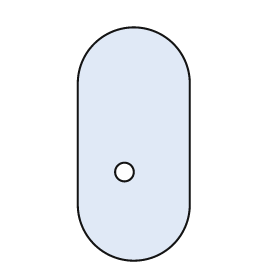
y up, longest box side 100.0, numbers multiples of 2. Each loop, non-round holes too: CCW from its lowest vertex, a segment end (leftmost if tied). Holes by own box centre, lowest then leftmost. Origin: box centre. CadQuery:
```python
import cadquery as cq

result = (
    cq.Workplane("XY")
    .moveTo(-24.0, -26.0)
    .threePointArc((0.0, -50.0), (24.0, -26.0))
    .lineTo(24.0, 26.0)
    .threePointArc((0.0, 50.0), (-24.0, 26.0))
    .close()
    .moveTo(-4.0, -12.0)
    .circle(4.0)
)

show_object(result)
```